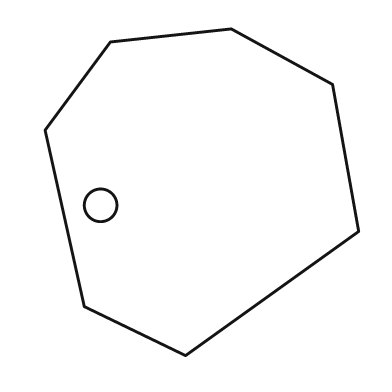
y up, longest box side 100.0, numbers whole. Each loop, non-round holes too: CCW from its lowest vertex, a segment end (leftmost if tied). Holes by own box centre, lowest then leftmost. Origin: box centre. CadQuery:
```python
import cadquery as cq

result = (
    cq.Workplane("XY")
    .moveTo(-5.0, -50.0)
    .lineTo(48.0, -12.0)
    .lineTo(40.0, 33.0)
    .lineTo(9.0, 50.0)
    .lineTo(-28.0, 46.0)
    .lineTo(-48.0, 19.0)
    .lineTo(-36.0, -35.0)
    .close()
    .moveTo(-31.0, -4.0)
    .circle(5.0)
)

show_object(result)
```